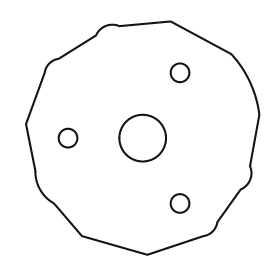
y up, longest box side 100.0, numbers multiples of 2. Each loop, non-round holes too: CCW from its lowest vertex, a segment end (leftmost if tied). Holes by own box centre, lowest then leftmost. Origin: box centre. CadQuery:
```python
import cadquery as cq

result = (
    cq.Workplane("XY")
    .moveTo(2.0, -50.0)
    .lineTo(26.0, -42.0)
    .threePointArc((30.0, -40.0), (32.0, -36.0))
    .lineTo(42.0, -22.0)
    .threePointArc((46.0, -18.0), (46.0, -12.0))
    .lineTo(50.0, 10.0)
    .threePointArc((46.0, 24.0), (38.0, 36.0))
    .lineTo(12.0, 50.0)
    .lineTo(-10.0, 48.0)
    .threePointArc((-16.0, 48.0), (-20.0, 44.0))
    .lineTo(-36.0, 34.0)
    .threePointArc((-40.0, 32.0), (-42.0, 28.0))
    .lineTo(-50.0, 6.0)
    .lineTo(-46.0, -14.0)
    .threePointArc((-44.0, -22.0), (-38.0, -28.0))
    .lineTo(-26.0, -42.0)
    .close()
    .moveTo(16.0, -28.0)
    .circle(4.0)
    .moveTo(-32.0, 0.0)
    .circle(4.0)
    .moveTo(0.0, 0.0)
    .circle(10.0)
    .moveTo(16.0, 28.0)
    .circle(4.0)
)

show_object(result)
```